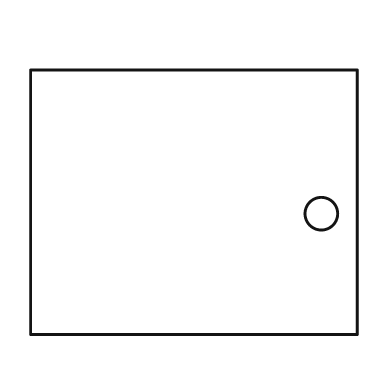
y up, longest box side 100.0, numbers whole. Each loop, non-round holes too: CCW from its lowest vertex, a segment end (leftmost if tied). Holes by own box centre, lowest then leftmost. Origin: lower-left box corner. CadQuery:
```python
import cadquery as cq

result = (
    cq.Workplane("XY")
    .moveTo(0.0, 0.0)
    .lineTo(100.0, 0.0)
    .lineTo(100.0, 81.0)
    .lineTo(0.0, 81.0)
    .close()
    .moveTo(89.0, 37.0)
    .circle(5.0)
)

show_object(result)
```